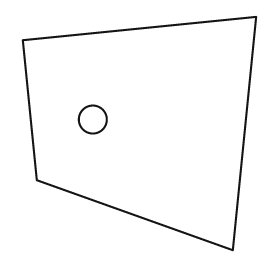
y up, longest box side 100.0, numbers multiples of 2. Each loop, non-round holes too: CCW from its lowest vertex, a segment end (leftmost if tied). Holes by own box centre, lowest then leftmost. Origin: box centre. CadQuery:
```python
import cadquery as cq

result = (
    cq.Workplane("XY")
    .moveTo(40.0, -50.0)
    .lineTo(50.0, 50.0)
    .lineTo(-50.0, 40.0)
    .lineTo(-44.0, -20.0)
    .close()
    .moveTo(-20.0, 6.0)
    .circle(6.0)
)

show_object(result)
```